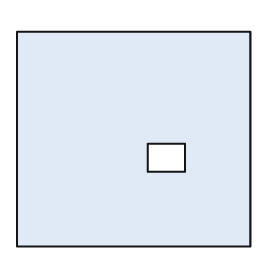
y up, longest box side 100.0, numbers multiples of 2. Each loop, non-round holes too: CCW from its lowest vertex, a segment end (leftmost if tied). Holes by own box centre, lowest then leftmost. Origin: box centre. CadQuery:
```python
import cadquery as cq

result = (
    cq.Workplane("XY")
    .moveTo(-50.0, -46.0)
    .lineTo(50.0, -46.0)
    .lineTo(50.0, 46.0)
    .lineTo(-50.0, 46.0)
    .close()
    .moveTo(6.0, -14.0)
    .lineTo(22.0, -14.0)
    .lineTo(22.0, -2.0)
    .lineTo(6.0, -2.0)
    .close()
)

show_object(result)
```